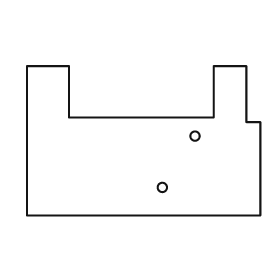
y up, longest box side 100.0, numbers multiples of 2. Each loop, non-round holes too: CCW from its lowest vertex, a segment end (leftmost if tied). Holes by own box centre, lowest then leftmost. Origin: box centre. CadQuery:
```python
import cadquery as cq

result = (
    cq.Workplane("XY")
    .moveTo(-50.0, -32.0)
    .lineTo(50.0, -32.0)
    .lineTo(50.0, 8.0)
    .lineTo(44.0, 8.0)
    .lineTo(44.0, 32.0)
    .lineTo(30.0, 32.0)
    .lineTo(30.0, 10.0)
    .lineTo(-32.0, 10.0)
    .lineTo(-32.0, 32.0)
    .lineTo(-50.0, 32.0)
    .close()
    .moveTo(8.0, -20.0)
    .circle(2.0)
    .moveTo(22.0, 2.0)
    .circle(2.0)
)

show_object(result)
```